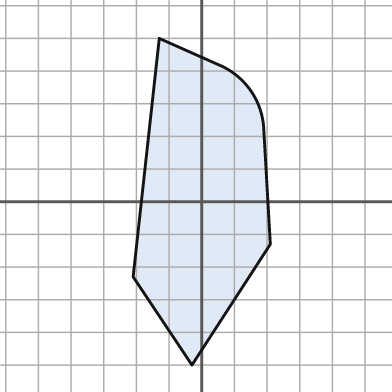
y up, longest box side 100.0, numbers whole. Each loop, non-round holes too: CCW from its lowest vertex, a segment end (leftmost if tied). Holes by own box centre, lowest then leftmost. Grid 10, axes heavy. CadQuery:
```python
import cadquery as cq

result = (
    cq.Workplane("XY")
    .moveTo(-3.0, -50.0)
    .lineTo(21.0, -13.0)
    .lineTo(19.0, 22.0)
    .threePointArc((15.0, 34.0), (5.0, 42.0))
    .lineTo(-13.0, 50.0)
    .lineTo(-21.0, -23.0)
    .close()
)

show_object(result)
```